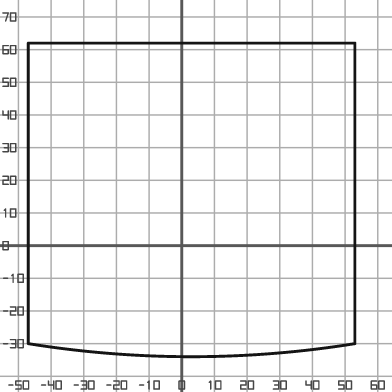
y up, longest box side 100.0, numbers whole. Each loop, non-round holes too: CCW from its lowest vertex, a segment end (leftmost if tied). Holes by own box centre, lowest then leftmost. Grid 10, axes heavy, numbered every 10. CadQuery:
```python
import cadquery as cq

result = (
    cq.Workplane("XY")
    .moveTo(-47.0, -30.0)
    .threePointArc((3.0, -34.0), (53.0, -30.0))
    .lineTo(53.0, 62.0)
    .lineTo(-47.0, 62.0)
    .close()
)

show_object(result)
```